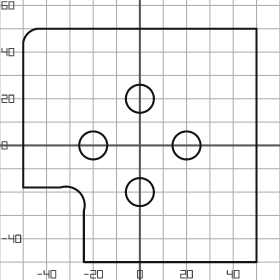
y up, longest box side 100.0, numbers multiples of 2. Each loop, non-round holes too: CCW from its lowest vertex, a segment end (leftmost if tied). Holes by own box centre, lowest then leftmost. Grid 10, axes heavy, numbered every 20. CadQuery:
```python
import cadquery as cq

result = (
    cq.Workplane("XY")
    .moveTo(-24.0, -50.0)
    .lineTo(50.0, -50.0)
    .lineTo(50.0, 50.0)
    .lineTo(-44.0, 50.0)
    .threePointArc((-48.0, 48.0), (-50.0, 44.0))
    .lineTo(-50.0, -18.0)
    .lineTo(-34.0, -18.0)
    .threePointArc((-26.0, -20.0), (-24.0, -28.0))
    .close()
    .moveTo(0.0, -20.0)
    .circle(6.0)
    .moveTo(-20.0, 0.0)
    .circle(6.0)
    .moveTo(20.0, 0.0)
    .circle(6.0)
    .moveTo(0.0, 20.0)
    .circle(6.0)
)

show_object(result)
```